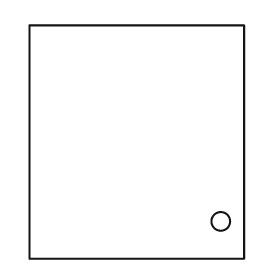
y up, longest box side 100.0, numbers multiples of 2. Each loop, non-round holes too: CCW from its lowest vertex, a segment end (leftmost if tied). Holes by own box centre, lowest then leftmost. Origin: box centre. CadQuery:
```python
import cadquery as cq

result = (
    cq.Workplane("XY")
    .moveTo(-46.0, -50.0)
    .lineTo(46.0, -50.0)
    .lineTo(46.0, 50.0)
    .lineTo(-46.0, 50.0)
    .close()
    .moveTo(36.0, -34.0)
    .circle(4.0)
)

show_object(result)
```